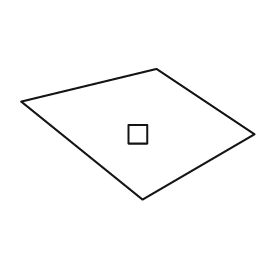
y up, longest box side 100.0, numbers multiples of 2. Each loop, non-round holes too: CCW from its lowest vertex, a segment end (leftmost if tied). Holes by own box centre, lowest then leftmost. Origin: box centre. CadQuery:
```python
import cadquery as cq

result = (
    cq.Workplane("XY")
    .moveTo(2.0, -28.0)
    .lineTo(50.0, 0.0)
    .lineTo(8.0, 28.0)
    .lineTo(-50.0, 14.0)
    .close()
    .moveTo(-4.0, -4.0)
    .lineTo(4.0, -4.0)
    .lineTo(4.0, 4.0)
    .lineTo(-4.0, 4.0)
    .close()
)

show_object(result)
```